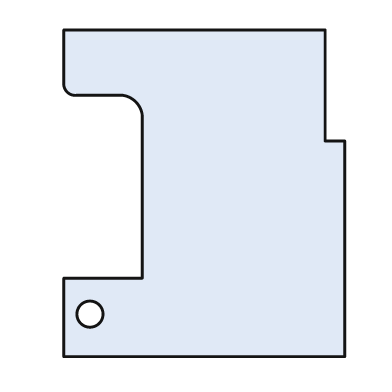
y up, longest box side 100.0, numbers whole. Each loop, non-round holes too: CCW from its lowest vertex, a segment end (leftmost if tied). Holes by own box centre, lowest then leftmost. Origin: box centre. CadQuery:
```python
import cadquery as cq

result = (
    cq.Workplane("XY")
    .moveTo(-43.0, -50.0)
    .lineTo(43.0, -50.0)
    .lineTo(43.0, 16.0)
    .lineTo(37.0, 16.0)
    .lineTo(37.0, 50.0)
    .lineTo(-43.0, 50.0)
    .lineTo(-43.0, 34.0)
    .threePointArc((-42.0, 31.0), (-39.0, 30.0))
    .lineTo(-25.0, 30.0)
    .threePointArc((-21.0, 28.0), (-19.0, 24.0))
    .lineTo(-19.0, -26.0)
    .lineTo(-43.0, -26.0)
    .close()
    .moveTo(-35.0, -37.0)
    .circle(4.0)
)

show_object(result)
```